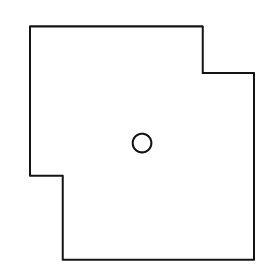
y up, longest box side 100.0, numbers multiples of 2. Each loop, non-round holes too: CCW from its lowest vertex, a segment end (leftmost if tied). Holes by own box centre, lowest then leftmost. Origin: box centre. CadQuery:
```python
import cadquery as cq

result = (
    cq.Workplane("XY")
    .moveTo(-34.0, -50.0)
    .lineTo(48.0, -50.0)
    .lineTo(48.0, 30.0)
    .lineTo(26.0, 30.0)
    .lineTo(26.0, 50.0)
    .lineTo(-48.0, 50.0)
    .lineTo(-48.0, -14.0)
    .lineTo(-34.0, -14.0)
    .close()
    .moveTo(0.0, 0.0)
    .circle(4.0)
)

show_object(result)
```